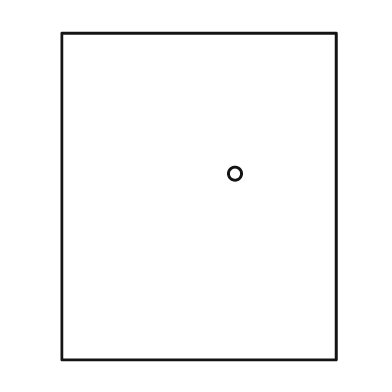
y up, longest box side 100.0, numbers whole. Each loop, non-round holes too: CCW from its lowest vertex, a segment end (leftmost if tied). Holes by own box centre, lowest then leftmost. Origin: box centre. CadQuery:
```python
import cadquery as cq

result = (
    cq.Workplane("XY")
    .moveTo(-42.0, -50.0)
    .lineTo(42.0, -50.0)
    .lineTo(42.0, 50.0)
    .lineTo(-42.0, 50.0)
    .close()
    .moveTo(11.0, 7.0)
    .circle(2.0)
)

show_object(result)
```